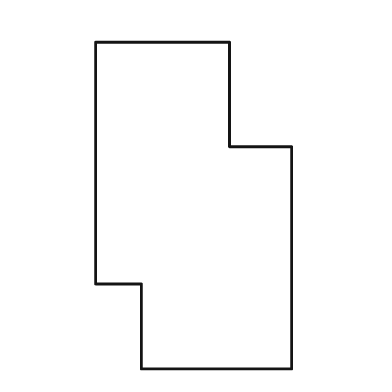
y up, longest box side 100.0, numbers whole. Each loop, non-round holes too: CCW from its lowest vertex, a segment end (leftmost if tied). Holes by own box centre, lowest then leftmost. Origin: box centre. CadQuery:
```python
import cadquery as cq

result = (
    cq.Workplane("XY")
    .moveTo(-16.0, -50.0)
    .lineTo(30.0, -50.0)
    .lineTo(30.0, 18.0)
    .lineTo(11.0, 18.0)
    .lineTo(11.0, 50.0)
    .lineTo(-30.0, 50.0)
    .lineTo(-30.0, -24.0)
    .lineTo(-16.0, -24.0)
    .close()
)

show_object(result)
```